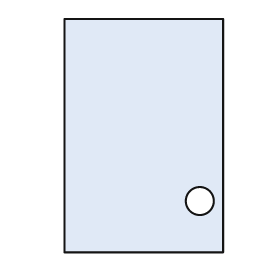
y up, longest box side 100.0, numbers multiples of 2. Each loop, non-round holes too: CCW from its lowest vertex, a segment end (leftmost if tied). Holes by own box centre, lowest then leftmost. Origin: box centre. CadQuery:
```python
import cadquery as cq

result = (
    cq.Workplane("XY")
    .moveTo(-34.0, -50.0)
    .lineTo(34.0, -50.0)
    .lineTo(34.0, 50.0)
    .lineTo(-34.0, 50.0)
    .close()
    .moveTo(24.0, -28.0)
    .circle(6.0)
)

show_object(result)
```